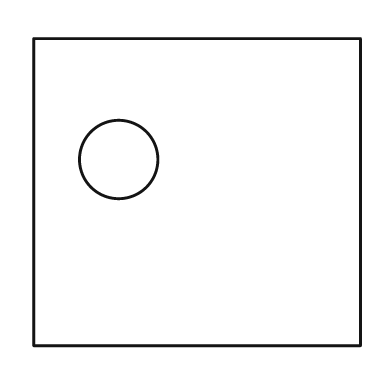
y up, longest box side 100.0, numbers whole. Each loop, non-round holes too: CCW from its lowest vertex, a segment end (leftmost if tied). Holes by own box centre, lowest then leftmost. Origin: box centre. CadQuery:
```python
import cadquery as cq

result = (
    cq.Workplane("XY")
    .moveTo(-50.0, -47.0)
    .lineTo(50.0, -47.0)
    .lineTo(50.0, 47.0)
    .lineTo(-50.0, 47.0)
    .close()
    .moveTo(-24.0, 10.0)
    .circle(12.0)
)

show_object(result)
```